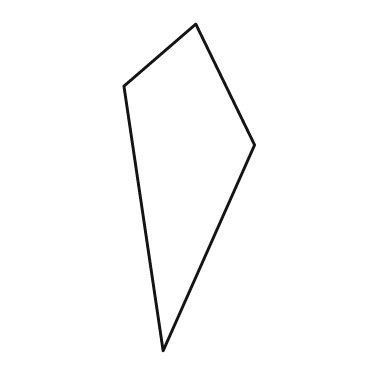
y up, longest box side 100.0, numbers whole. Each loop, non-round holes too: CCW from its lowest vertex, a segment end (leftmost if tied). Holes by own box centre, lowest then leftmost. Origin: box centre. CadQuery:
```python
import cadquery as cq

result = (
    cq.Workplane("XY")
    .moveTo(-8.0, -50.0)
    .lineTo(20.0, 13.0)
    .lineTo(2.0, 50.0)
    .lineTo(-20.0, 31.0)
    .close()
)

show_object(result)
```